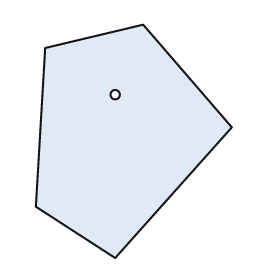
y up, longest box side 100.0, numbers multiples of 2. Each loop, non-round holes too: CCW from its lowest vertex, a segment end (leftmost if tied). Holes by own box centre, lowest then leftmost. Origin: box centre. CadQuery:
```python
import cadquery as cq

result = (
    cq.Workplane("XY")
    .moveTo(-8.0, -50.0)
    .lineTo(42.0, 6.0)
    .lineTo(4.0, 50.0)
    .lineTo(-38.0, 40.0)
    .lineTo(-42.0, -28.0)
    .close()
    .moveTo(-8.0, 20.0)
    .circle(2.0)
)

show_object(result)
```